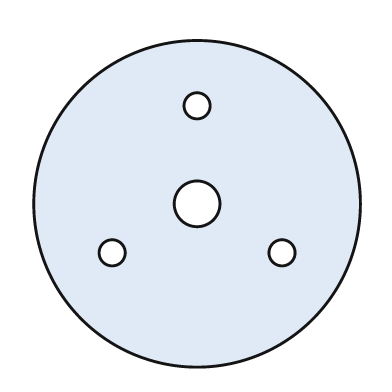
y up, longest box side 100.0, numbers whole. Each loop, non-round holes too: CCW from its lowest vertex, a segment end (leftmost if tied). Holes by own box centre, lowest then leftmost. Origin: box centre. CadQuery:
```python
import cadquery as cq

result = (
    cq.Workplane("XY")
    .moveTo(0.0, 0.0)
    .circle(50.0)
    .moveTo(-26.0, -15.0)
    .circle(4.0)
    .moveTo(26.0, -15.0)
    .circle(4.0)
    .moveTo(0.0, 0.0)
    .circle(7.0)
    .moveTo(0.0, 30.0)
    .circle(4.0)
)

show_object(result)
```